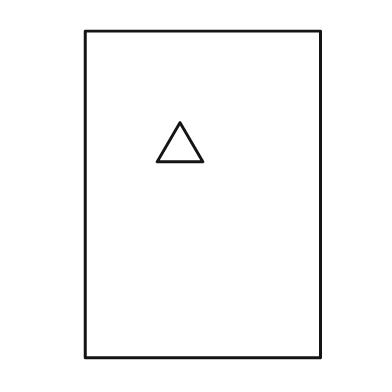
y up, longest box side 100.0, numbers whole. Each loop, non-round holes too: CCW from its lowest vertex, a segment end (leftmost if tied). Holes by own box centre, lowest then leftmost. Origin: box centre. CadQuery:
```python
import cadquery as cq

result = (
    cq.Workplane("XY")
    .moveTo(-36.0, -50.0)
    .lineTo(36.0, -50.0)
    .lineTo(36.0, 50.0)
    .lineTo(-36.0, 50.0)
    .close()
    .moveTo(-14.0, 10.0)
    .lineTo(0.0, 10.0)
    .lineTo(-7.0, 22.0)
    .close()
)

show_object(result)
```